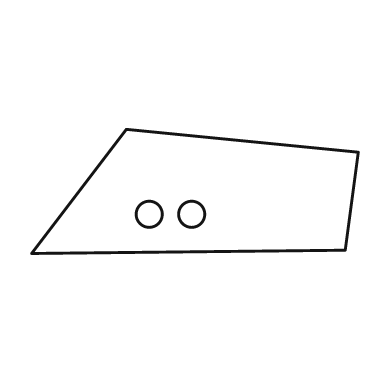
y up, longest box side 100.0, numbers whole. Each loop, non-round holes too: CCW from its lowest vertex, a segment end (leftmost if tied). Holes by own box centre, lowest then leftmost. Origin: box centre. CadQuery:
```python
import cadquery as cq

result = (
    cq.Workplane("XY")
    .moveTo(-50.0, -19.0)
    .lineTo(46.0, -18.0)
    .lineTo(50.0, 12.0)
    .lineTo(-21.0, 19.0)
    .close()
    .moveTo(-14.0, -7.0)
    .circle(4.0)
    .moveTo(-1.0, -7.0)
    .circle(4.0)
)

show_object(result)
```